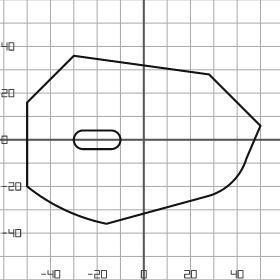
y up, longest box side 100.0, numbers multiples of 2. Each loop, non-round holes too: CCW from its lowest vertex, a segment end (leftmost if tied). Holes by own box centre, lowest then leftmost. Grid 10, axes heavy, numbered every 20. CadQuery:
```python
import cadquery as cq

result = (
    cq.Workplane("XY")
    .moveTo(-16.0, -36.0)
    .lineTo(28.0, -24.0)
    .threePointArc((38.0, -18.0), (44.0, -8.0))
    .lineTo(50.0, 6.0)
    .lineTo(28.0, 28.0)
    .lineTo(-30.0, 36.0)
    .lineTo(-50.0, 16.0)
    .lineTo(-50.0, -20.0)
    .threePointArc((-34.0, -30.0), (-16.0, -36.0))
    .close()
    .moveTo(-26.0, -4.0)
    .lineTo(-14.0, -4.0)
    .threePointArc((-10.0, 0.0), (-14.0, 4.0))
    .lineTo(-26.0, 4.0)
    .threePointArc((-30.0, 0.0), (-26.0, -4.0))
    .close()
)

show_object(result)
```